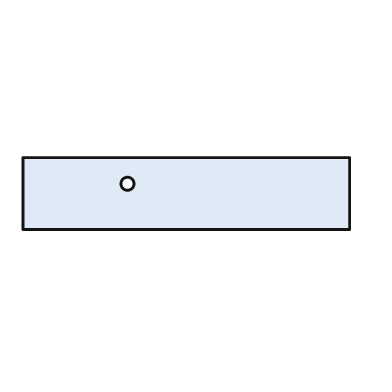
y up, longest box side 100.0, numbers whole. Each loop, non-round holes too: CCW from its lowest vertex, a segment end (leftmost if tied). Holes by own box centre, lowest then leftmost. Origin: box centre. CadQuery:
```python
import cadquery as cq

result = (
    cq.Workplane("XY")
    .moveTo(-50.0, -11.0)
    .lineTo(50.0, -11.0)
    .lineTo(50.0, 11.0)
    .lineTo(-50.0, 11.0)
    .close()
    .moveTo(-18.0, 3.0)
    .circle(2.0)
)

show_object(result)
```